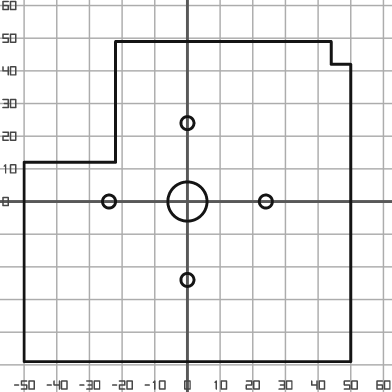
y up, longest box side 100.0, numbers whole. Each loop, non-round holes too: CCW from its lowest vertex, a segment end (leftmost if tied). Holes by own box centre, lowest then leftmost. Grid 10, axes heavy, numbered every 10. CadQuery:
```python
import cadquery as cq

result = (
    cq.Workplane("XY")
    .moveTo(-50.0, -49.0)
    .lineTo(50.0, -49.0)
    .lineTo(50.0, 42.0)
    .lineTo(44.0, 42.0)
    .lineTo(44.0, 49.0)
    .lineTo(-22.0, 49.0)
    .lineTo(-22.0, 12.0)
    .lineTo(-50.0, 12.0)
    .close()
    .moveTo(0.0, -24.0)
    .circle(2.0)
    .moveTo(-24.0, 0.0)
    .circle(2.0)
    .moveTo(0.0, 0.0)
    .circle(6.0)
    .moveTo(24.0, 0.0)
    .circle(2.0)
    .moveTo(0.0, 24.0)
    .circle(2.0)
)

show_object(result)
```